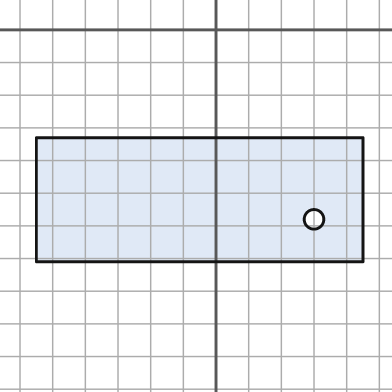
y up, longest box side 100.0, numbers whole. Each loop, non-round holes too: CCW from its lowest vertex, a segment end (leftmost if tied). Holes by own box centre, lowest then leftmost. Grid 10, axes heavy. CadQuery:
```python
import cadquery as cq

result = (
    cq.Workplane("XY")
    .moveTo(-55.0, -71.0)
    .lineTo(45.0, -71.0)
    .lineTo(45.0, -33.0)
    .lineTo(-55.0, -33.0)
    .close()
    .moveTo(30.0, -58.0)
    .circle(3.0)
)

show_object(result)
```